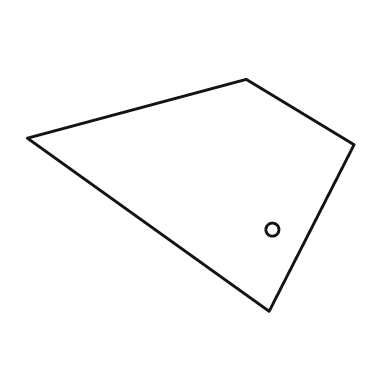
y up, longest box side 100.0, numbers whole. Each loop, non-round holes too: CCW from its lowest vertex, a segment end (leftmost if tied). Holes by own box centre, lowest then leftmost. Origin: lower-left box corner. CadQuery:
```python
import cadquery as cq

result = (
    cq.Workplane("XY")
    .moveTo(74.0, 0.0)
    .lineTo(100.0, 51.0)
    .lineTo(67.0, 71.0)
    .lineTo(0.0, 53.0)
    .close()
    .moveTo(75.0, 25.0)
    .circle(2.0)
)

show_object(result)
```